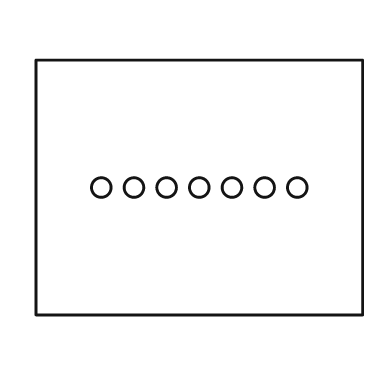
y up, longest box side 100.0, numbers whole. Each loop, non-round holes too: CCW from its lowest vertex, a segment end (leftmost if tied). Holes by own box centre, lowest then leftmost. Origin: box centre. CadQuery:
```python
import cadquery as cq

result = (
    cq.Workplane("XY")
    .moveTo(-50.0, -39.0)
    .lineTo(50.0, -39.0)
    .lineTo(50.0, 39.0)
    .lineTo(-50.0, 39.0)
    .close()
    .moveTo(-30.0, 0.0)
    .circle(3.0)
    .moveTo(-20.0, 0.0)
    .circle(3.0)
    .moveTo(-10.0, 0.0)
    .circle(3.0)
    .moveTo(0.0, 0.0)
    .circle(3.0)
    .moveTo(10.0, 0.0)
    .circle(3.0)
    .moveTo(20.0, 0.0)
    .circle(3.0)
    .moveTo(30.0, 0.0)
    .circle(3.0)
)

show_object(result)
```